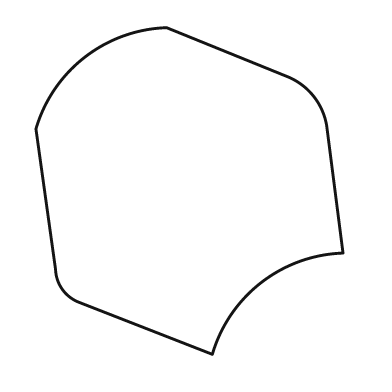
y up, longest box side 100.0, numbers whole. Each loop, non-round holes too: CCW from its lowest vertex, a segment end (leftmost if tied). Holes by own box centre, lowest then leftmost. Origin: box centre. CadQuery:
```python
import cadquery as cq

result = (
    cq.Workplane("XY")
    .moveTo(7.0, -50.0)
    .threePointArc((22.0, -28.0), (47.0, -19.0))
    .lineTo(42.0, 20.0)
    .threePointArc((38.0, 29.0), (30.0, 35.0))
    .lineTo(-7.0, 50.0)
    .threePointArc((-32.0, 41.0), (-47.0, 19.0))
    .lineTo(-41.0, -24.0)
    .threePointArc((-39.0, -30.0), (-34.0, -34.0))
    .close()
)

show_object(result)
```